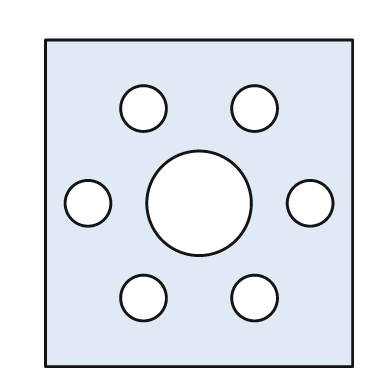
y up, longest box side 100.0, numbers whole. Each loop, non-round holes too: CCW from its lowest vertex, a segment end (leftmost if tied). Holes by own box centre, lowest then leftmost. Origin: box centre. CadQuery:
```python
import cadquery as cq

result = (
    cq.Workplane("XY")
    .moveTo(-47.0, -50.0)
    .lineTo(47.0, -50.0)
    .lineTo(47.0, 50.0)
    .lineTo(-47.0, 50.0)
    .close()
    .moveTo(-17.0, -29.0)
    .circle(7.0)
    .moveTo(17.0, -29.0)
    .circle(7.0)
    .moveTo(-34.0, 0.0)
    .circle(7.0)
    .moveTo(0.0, 0.0)
    .circle(16.0)
    .moveTo(34.0, 0.0)
    .circle(7.0)
    .moveTo(-17.0, 29.0)
    .circle(7.0)
    .moveTo(17.0, 29.0)
    .circle(7.0)
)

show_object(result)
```